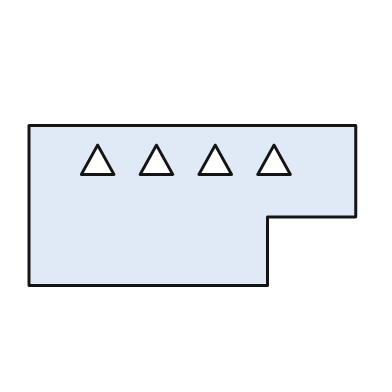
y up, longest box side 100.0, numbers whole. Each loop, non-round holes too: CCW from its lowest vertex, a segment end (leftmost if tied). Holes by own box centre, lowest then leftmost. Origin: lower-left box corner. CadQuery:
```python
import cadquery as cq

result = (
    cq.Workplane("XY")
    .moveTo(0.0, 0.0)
    .lineTo(73.0, 0.0)
    .lineTo(73.0, 21.0)
    .lineTo(100.0, 21.0)
    .lineTo(100.0, 49.0)
    .lineTo(0.0, 49.0)
    .close()
    .moveTo(16.0, 34.0)
    .lineTo(26.0, 34.0)
    .lineTo(21.0, 43.0)
    .close()
    .moveTo(34.0, 34.0)
    .lineTo(44.0, 34.0)
    .lineTo(39.0, 43.0)
    .close()
    .moveTo(52.0, 34.0)
    .lineTo(62.0, 34.0)
    .lineTo(57.0, 43.0)
    .close()
    .moveTo(70.0, 34.0)
    .lineTo(80.0, 34.0)
    .lineTo(75.0, 43.0)
    .close()
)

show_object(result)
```